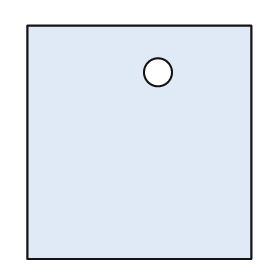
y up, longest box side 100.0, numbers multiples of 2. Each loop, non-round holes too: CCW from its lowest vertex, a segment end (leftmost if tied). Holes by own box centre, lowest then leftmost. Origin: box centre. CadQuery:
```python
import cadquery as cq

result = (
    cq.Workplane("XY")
    .moveTo(-48.0, -50.0)
    .lineTo(48.0, -50.0)
    .lineTo(48.0, 50.0)
    .lineTo(-48.0, 50.0)
    .close()
    .moveTo(8.0, 30.0)
    .circle(6.0)
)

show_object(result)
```